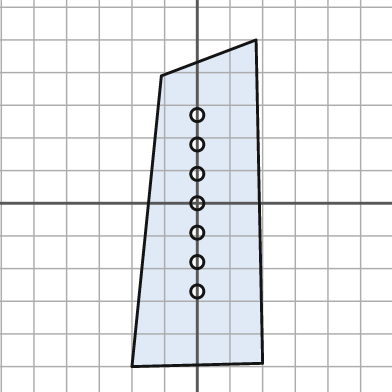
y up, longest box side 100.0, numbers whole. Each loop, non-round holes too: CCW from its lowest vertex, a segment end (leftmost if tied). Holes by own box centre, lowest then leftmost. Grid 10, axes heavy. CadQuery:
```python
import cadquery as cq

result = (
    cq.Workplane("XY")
    .moveTo(-20.0, -50.0)
    .lineTo(20.0, -49.0)
    .lineTo(18.0, 50.0)
    .lineTo(-11.0, 39.0)
    .close()
    .moveTo(0.0, -27.0)
    .circle(2.0)
    .moveTo(0.0, -18.0)
    .circle(2.0)
    .moveTo(0.0, -9.0)
    .circle(2.0)
    .moveTo(0.0, 0.0)
    .circle(2.0)
    .moveTo(0.0, 9.0)
    .circle(2.0)
    .moveTo(0.0, 18.0)
    .circle(2.0)
    .moveTo(0.0, 27.0)
    .circle(2.0)
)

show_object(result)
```